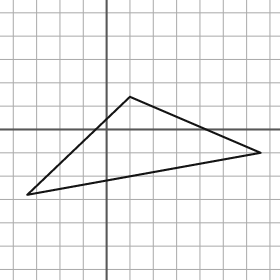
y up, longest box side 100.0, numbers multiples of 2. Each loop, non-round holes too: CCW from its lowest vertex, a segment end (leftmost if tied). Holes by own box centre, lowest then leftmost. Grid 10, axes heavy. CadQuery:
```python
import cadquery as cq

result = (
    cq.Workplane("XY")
    .moveTo(-34.0, -28.0)
    .lineTo(66.0, -10.0)
    .lineTo(10.0, 14.0)
    .close()
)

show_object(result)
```